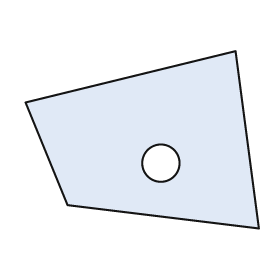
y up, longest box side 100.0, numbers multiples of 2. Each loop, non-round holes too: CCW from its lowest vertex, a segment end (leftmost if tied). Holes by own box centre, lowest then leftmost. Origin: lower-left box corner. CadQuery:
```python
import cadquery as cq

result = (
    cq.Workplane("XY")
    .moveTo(100.0, 0.0)
    .lineTo(90.0, 76.0)
    .lineTo(0.0, 54.0)
    .lineTo(18.0, 10.0)
    .close()
    .moveTo(58.0, 28.0)
    .circle(8.0)
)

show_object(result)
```